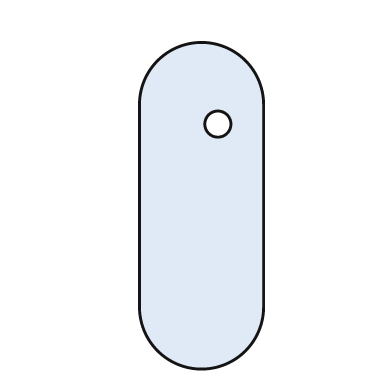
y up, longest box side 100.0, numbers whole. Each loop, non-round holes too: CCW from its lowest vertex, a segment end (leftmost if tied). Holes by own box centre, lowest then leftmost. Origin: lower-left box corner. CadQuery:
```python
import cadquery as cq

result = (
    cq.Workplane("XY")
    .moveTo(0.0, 19.0)
    .threePointArc((19.0, 0.0), (38.0, 19.0))
    .lineTo(38.0, 81.0)
    .threePointArc((19.0, 100.0), (0.0, 81.0))
    .close()
    .moveTo(24.0, 75.0)
    .circle(4.0)
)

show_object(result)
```